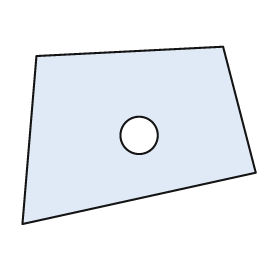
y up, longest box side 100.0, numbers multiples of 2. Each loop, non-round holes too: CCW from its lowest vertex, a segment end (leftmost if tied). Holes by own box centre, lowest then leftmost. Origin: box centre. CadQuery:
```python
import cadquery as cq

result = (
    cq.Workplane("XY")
    .moveTo(-50.0, -38.0)
    .lineTo(50.0, -16.0)
    .lineTo(36.0, 38.0)
    .lineTo(-44.0, 34.0)
    .close()
    .moveTo(0.0, 0.0)
    .circle(8.0)
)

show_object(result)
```